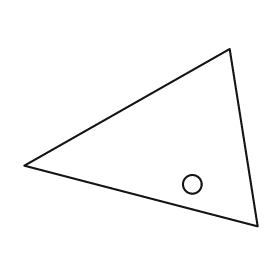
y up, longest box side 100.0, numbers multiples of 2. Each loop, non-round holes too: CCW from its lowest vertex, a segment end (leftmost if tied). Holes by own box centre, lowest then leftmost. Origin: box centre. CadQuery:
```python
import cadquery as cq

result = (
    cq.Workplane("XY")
    .moveTo(50.0, -38.0)
    .lineTo(38.0, 38.0)
    .lineTo(-50.0, -12.0)
    .close()
    .moveTo(22.0, -20.0)
    .circle(4.0)
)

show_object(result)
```